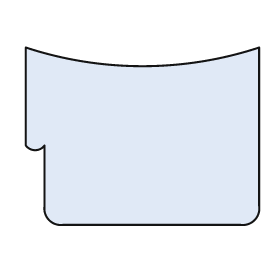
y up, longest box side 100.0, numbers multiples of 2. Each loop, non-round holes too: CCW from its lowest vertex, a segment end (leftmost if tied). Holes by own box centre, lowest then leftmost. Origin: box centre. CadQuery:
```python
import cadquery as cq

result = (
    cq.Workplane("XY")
    .moveTo(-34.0, -38.0)
    .lineTo(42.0, -38.0)
    .threePointArc((48.0, -36.0), (50.0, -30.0))
    .lineTo(50.0, 38.0)
    .threePointArc((0.0, 30.0), (-50.0, 38.0))
    .lineTo(-50.0, -4.0)
    .threePointArc((-46.0, -6.0), (-42.0, -4.0))
    .lineTo(-42.0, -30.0)
    .threePointArc((-40.0, -36.0), (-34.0, -38.0))
    .close()
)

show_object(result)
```